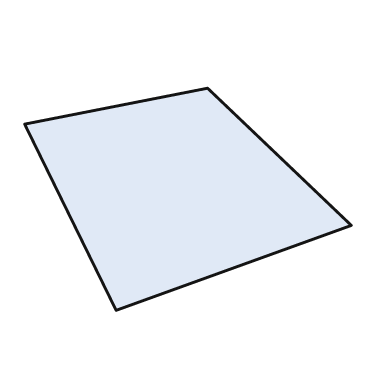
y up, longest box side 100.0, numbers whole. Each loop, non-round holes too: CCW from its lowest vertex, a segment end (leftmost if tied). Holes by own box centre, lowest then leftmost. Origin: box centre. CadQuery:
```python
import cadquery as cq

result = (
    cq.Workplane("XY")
    .moveTo(-22.0, -34.0)
    .lineTo(50.0, -8.0)
    .lineTo(6.0, 34.0)
    .lineTo(-50.0, 23.0)
    .close()
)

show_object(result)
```